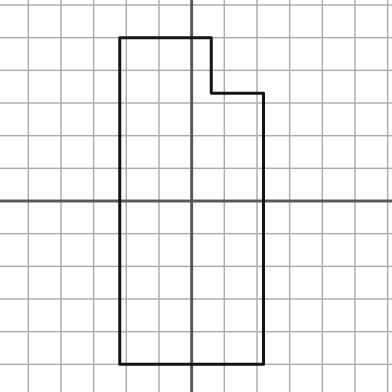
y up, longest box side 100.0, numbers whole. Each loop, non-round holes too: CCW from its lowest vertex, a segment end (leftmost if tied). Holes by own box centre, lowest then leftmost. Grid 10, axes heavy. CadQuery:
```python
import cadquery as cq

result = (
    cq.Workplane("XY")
    .moveTo(-22.0, -50.0)
    .lineTo(22.0, -50.0)
    .lineTo(22.0, 33.0)
    .lineTo(6.0, 33.0)
    .lineTo(6.0, 50.0)
    .lineTo(-22.0, 50.0)
    .close()
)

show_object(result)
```